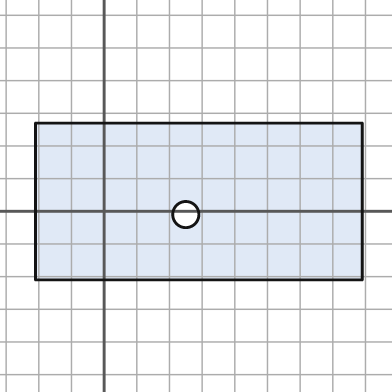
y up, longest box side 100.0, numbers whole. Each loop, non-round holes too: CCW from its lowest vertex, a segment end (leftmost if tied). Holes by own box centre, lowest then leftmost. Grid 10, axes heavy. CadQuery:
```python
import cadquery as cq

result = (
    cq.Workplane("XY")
    .moveTo(-21.0, -21.0)
    .lineTo(79.0, -21.0)
    .lineTo(79.0, 27.0)
    .lineTo(-21.0, 27.0)
    .close()
    .moveTo(25.0, -1.0)
    .circle(4.0)
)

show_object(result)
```